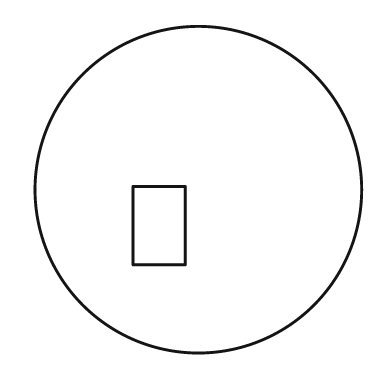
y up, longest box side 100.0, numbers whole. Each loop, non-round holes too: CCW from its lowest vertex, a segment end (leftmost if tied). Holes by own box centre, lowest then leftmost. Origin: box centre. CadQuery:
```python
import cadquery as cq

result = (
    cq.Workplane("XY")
    .moveTo(0.0, 0.0)
    .circle(50.0)
    .moveTo(-20.0, -23.0)
    .lineTo(-4.0, -23.0)
    .lineTo(-4.0, 1.0)
    .lineTo(-20.0, 1.0)
    .close()
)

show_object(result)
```